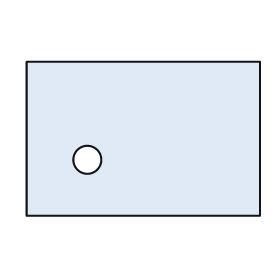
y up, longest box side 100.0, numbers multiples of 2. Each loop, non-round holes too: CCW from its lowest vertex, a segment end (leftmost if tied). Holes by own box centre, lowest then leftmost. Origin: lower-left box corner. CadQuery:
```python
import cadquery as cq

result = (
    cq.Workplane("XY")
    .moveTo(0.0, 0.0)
    .lineTo(100.0, 0.0)
    .lineTo(100.0, 66.0)
    .lineTo(0.0, 66.0)
    .close()
    .moveTo(26.0, 24.0)
    .circle(6.0)
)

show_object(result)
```